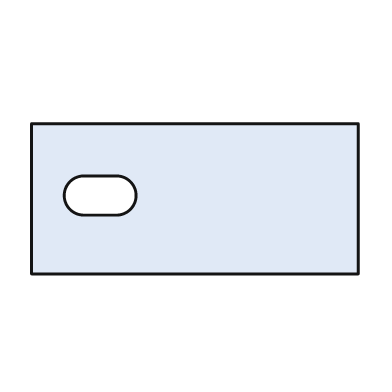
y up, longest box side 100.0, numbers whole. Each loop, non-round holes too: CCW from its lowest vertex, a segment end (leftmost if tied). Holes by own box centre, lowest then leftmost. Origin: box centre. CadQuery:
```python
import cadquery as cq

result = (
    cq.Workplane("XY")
    .moveTo(-50.0, -23.0)
    .lineTo(50.0, -23.0)
    .lineTo(50.0, 23.0)
    .lineTo(-50.0, 23.0)
    .close()
    .moveTo(-34.0, -5.0)
    .lineTo(-24.0, -5.0)
    .threePointArc((-18.0, 1.0), (-24.0, 7.0))
    .lineTo(-34.0, 7.0)
    .threePointArc((-40.0, 1.0), (-34.0, -5.0))
    .close()
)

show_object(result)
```